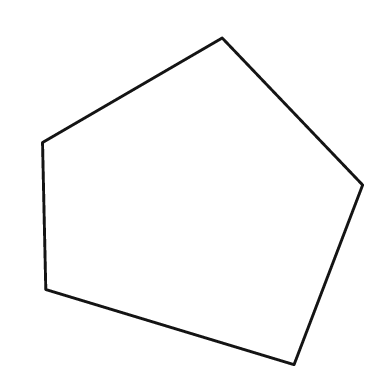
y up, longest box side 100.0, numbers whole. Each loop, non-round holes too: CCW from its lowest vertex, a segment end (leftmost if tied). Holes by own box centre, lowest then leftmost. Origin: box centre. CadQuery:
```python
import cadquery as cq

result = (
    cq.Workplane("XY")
    .moveTo(28.0, -50.0)
    .lineTo(49.0, 5.0)
    .lineTo(6.0, 50.0)
    .lineTo(-49.0, 18.0)
    .lineTo(-48.0, -27.0)
    .close()
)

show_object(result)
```